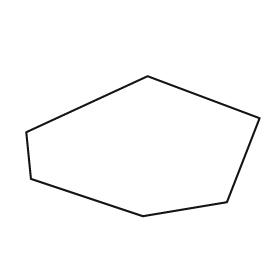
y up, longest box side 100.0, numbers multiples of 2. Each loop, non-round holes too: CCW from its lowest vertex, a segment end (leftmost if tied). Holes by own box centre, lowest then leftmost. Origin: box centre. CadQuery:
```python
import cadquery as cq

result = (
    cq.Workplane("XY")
    .moveTo(0.0, -30.0)
    .lineTo(36.0, -24.0)
    .lineTo(50.0, 12.0)
    .lineTo(2.0, 30.0)
    .lineTo(-50.0, 6.0)
    .lineTo(-48.0, -14.0)
    .close()
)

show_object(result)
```